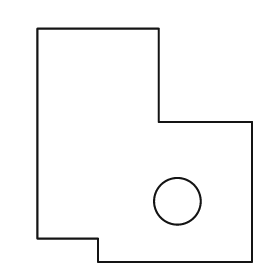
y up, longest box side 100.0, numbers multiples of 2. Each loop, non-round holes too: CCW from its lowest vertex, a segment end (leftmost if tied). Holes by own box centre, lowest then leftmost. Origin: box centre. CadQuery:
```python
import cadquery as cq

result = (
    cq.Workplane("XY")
    .moveTo(-20.0, -50.0)
    .lineTo(46.0, -50.0)
    .lineTo(46.0, 10.0)
    .lineTo(6.0, 10.0)
    .lineTo(6.0, 50.0)
    .lineTo(-46.0, 50.0)
    .lineTo(-46.0, -40.0)
    .lineTo(-20.0, -40.0)
    .close()
    .moveTo(14.0, -24.0)
    .circle(10.0)
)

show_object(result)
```